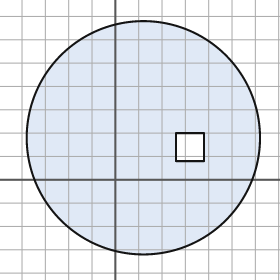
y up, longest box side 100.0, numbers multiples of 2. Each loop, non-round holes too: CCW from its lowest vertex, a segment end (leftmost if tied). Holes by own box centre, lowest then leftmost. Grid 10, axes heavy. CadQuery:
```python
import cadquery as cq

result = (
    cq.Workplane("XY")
    .moveTo(12.0, 18.0)
    .circle(50.0)
    .moveTo(26.0, 8.0)
    .lineTo(38.0, 8.0)
    .lineTo(38.0, 20.0)
    .lineTo(26.0, 20.0)
    .close()
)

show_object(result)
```